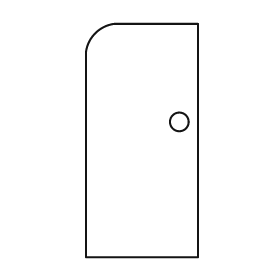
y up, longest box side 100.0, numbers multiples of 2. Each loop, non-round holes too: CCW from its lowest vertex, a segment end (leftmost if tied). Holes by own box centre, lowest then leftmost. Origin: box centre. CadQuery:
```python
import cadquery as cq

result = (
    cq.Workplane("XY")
    .moveTo(-24.0, -50.0)
    .lineTo(24.0, -50.0)
    .lineTo(24.0, 50.0)
    .lineTo(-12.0, 50.0)
    .threePointArc((-20.0, 46.0), (-24.0, 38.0))
    .close()
    .moveTo(16.0, 8.0)
    .circle(4.0)
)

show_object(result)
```